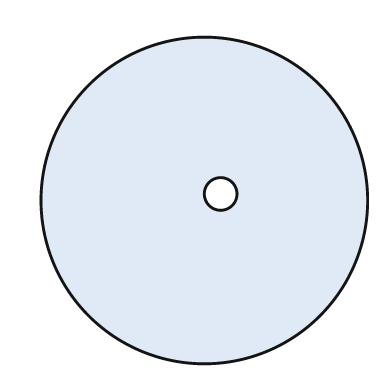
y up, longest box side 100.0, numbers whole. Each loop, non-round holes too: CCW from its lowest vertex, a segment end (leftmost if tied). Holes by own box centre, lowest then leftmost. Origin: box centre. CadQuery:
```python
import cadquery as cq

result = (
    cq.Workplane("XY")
    .moveTo(0.0, 0.0)
    .circle(50.0)
    .moveTo(5.0, 2.0)
    .circle(5.0)
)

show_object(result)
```